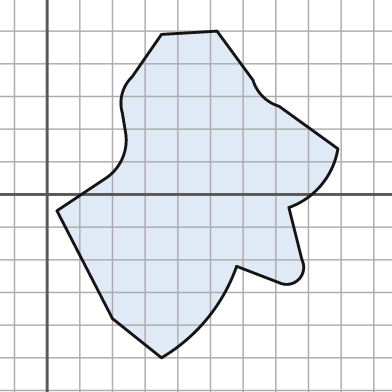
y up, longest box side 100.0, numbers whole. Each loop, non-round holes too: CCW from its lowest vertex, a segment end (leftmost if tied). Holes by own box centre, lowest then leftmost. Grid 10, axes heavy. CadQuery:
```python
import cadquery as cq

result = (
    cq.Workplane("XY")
    .moveTo(35.0, -50.0)
    .threePointArc((49.0, -38.0), (58.0, -22.0))
    .lineTo(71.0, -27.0)
    .threePointArc((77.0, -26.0), (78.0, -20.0))
    .lineTo(74.0, -4.0)
    .threePointArc((84.0, 3.0), (89.0, 14.0))
    .lineTo(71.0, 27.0)
    .threePointArc((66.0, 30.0), (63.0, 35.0))
    .lineTo(52.0, 50.0)
    .lineTo(35.0, 49.0)
    .lineTo(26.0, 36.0)
    .threePointArc((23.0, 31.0), (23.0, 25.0))
    .lineTo(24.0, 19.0)
    .threePointArc((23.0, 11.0), (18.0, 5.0))
    .lineTo(3.0, -5.0)
    .lineTo(20.0, -38.0)
    .close()
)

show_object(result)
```